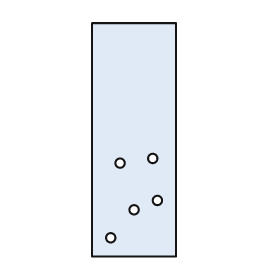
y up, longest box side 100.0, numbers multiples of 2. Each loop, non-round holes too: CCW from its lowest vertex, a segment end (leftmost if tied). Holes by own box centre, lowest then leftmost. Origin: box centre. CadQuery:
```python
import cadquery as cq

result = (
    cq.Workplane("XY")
    .moveTo(-18.0, -50.0)
    .lineTo(18.0, -50.0)
    .lineTo(18.0, 50.0)
    .lineTo(-18.0, 50.0)
    .close()
    .moveTo(-10.0, -42.0)
    .circle(2.0)
    .moveTo(0.0, -30.0)
    .circle(2.0)
    .moveTo(10.0, -26.0)
    .circle(2.0)
    .moveTo(-6.0, -10.0)
    .circle(2.0)
    .moveTo(8.0, -8.0)
    .circle(2.0)
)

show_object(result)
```